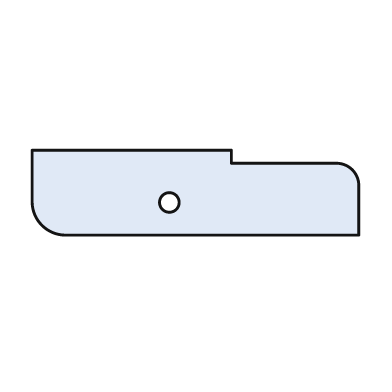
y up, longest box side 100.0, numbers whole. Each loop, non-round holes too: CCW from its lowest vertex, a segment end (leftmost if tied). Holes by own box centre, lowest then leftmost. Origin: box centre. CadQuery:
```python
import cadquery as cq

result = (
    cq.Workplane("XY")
    .moveTo(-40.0, -13.0)
    .lineTo(50.0, -13.0)
    .lineTo(50.0, 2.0)
    .threePointArc((48.0, 7.0), (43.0, 9.0))
    .lineTo(11.0, 9.0)
    .lineTo(11.0, 13.0)
    .lineTo(-50.0, 13.0)
    .lineTo(-50.0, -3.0)
    .threePointArc((-47.0, -10.0), (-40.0, -13.0))
    .close()
    .moveTo(-8.0, -3.0)
    .circle(3.0)
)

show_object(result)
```